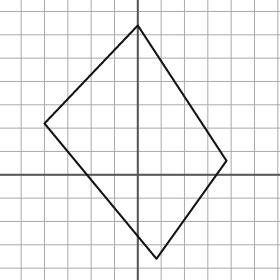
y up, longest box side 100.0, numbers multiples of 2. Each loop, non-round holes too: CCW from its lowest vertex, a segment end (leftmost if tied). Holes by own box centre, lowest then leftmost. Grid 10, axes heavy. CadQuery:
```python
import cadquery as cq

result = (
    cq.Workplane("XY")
    .moveTo(8.0, -36.0)
    .lineTo(38.0, 6.0)
    .lineTo(0.0, 64.0)
    .lineTo(-40.0, 22.0)
    .close()
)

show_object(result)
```